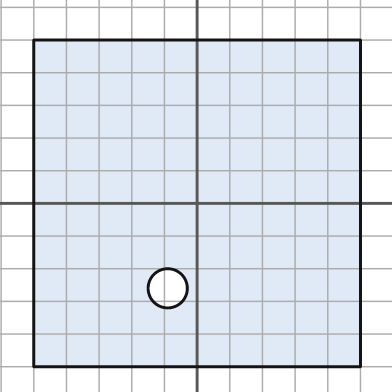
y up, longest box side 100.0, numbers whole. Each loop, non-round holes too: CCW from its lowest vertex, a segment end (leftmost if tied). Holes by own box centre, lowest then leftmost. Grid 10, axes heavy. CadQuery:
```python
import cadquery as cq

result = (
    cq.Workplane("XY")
    .moveTo(-50.0, -50.0)
    .lineTo(50.0, -50.0)
    .lineTo(50.0, 50.0)
    .lineTo(-50.0, 50.0)
    .close()
    .moveTo(-9.0, -26.0)
    .circle(6.0)
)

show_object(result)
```